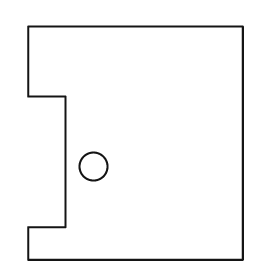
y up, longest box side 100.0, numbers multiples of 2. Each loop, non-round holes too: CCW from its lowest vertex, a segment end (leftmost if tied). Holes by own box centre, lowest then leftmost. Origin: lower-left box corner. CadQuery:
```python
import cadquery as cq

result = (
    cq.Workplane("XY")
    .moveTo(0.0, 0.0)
    .lineTo(92.0, 0.0)
    .lineTo(92.0, 100.0)
    .lineTo(0.0, 100.0)
    .lineTo(0.0, 70.0)
    .lineTo(16.0, 70.0)
    .lineTo(16.0, 14.0)
    .lineTo(0.0, 14.0)
    .close()
    .moveTo(28.0, 40.0)
    .circle(6.0)
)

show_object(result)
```